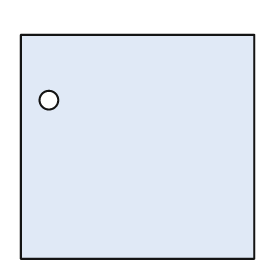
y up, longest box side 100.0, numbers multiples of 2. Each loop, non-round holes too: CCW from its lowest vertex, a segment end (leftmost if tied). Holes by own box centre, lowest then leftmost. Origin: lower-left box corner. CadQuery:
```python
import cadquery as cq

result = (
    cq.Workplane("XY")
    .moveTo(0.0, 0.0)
    .lineTo(100.0, 0.0)
    .lineTo(100.0, 96.0)
    .lineTo(0.0, 96.0)
    .close()
    .moveTo(12.0, 68.0)
    .circle(4.0)
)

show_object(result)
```